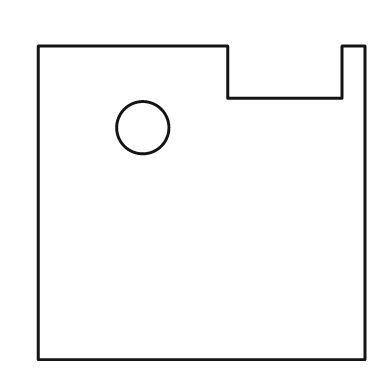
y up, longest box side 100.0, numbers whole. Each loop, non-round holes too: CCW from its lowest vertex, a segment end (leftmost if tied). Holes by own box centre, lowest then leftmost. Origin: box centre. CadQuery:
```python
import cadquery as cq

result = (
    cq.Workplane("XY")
    .moveTo(-50.0, -48.0)
    .lineTo(50.0, -48.0)
    .lineTo(50.0, 48.0)
    .lineTo(43.0, 48.0)
    .lineTo(43.0, 32.0)
    .lineTo(8.0, 32.0)
    .lineTo(8.0, 48.0)
    .lineTo(-50.0, 48.0)
    .close()
    .moveTo(-18.0, 23.0)
    .circle(8.0)
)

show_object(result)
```